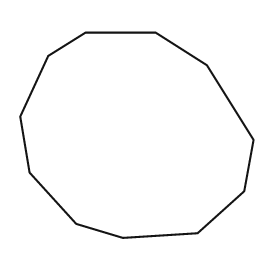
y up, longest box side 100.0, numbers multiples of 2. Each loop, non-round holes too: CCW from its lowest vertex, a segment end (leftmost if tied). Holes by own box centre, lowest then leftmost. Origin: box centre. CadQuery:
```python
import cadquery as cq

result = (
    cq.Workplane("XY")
    .moveTo(-6.0, -44.0)
    .lineTo(26.0, -42.0)
    .lineTo(46.0, -24.0)
    .lineTo(50.0, -2.0)
    .lineTo(30.0, 30.0)
    .lineTo(8.0, 44.0)
    .lineTo(-22.0, 44.0)
    .lineTo(-38.0, 34.0)
    .lineTo(-50.0, 8.0)
    .lineTo(-46.0, -16.0)
    .lineTo(-26.0, -38.0)
    .close()
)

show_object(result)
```